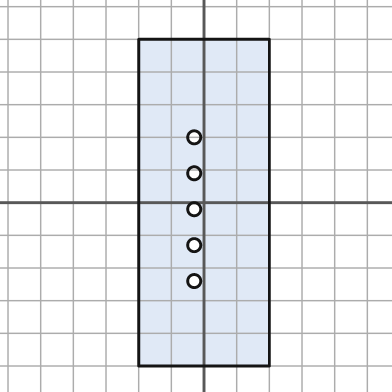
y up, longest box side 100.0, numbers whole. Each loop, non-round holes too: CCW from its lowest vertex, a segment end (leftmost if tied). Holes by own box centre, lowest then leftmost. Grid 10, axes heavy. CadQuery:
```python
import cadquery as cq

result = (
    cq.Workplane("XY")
    .moveTo(-20.0, -50.0)
    .lineTo(20.0, -50.0)
    .lineTo(20.0, 50.0)
    .lineTo(-20.0, 50.0)
    .close()
    .moveTo(-3.0, -24.0)
    .circle(2.0)
    .moveTo(-3.0, -13.0)
    .circle(2.0)
    .moveTo(-3.0, -2.0)
    .circle(2.0)
    .moveTo(-3.0, 9.0)
    .circle(2.0)
    .moveTo(-3.0, 20.0)
    .circle(2.0)
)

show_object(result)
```